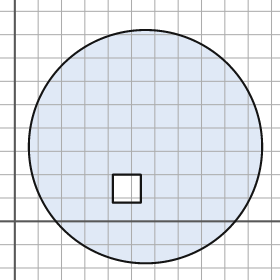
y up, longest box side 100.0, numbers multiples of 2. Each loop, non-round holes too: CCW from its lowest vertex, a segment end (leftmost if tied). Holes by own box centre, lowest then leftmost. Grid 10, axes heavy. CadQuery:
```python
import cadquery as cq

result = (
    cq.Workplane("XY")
    .moveTo(56.0, 32.0)
    .circle(50.0)
    .moveTo(42.0, 8.0)
    .lineTo(54.0, 8.0)
    .lineTo(54.0, 20.0)
    .lineTo(42.0, 20.0)
    .close()
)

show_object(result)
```